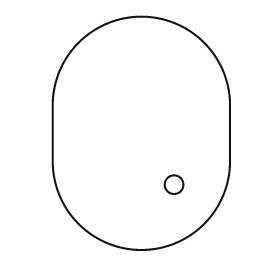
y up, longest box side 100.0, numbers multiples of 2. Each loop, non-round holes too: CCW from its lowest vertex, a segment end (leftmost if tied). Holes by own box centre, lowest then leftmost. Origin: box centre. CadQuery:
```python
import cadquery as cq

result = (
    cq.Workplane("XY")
    .moveTo(-38.0, -12.0)
    .threePointArc((0.0, -50.0), (38.0, -12.0))
    .lineTo(38.0, 12.0)
    .threePointArc((0.0, 50.0), (-38.0, 12.0))
    .close()
    .moveTo(14.0, -22.0)
    .circle(4.0)
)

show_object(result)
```